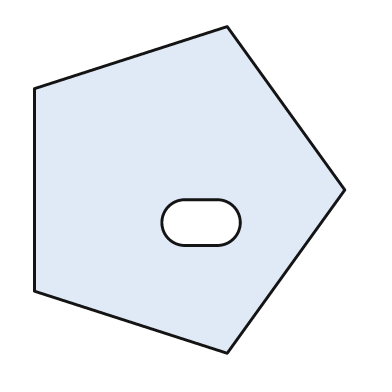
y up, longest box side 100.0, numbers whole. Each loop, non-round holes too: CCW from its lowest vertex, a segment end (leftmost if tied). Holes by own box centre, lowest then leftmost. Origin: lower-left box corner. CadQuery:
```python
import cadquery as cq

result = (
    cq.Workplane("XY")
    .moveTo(59.0, 0.0)
    .lineTo(95.0, 50.0)
    .lineTo(59.0, 100.0)
    .lineTo(0.0, 81.0)
    .lineTo(0.0, 19.0)
    .close()
    .moveTo(46.0, 33.0)
    .lineTo(56.0, 33.0)
    .threePointArc((63.0, 40.0), (56.0, 47.0))
    .lineTo(46.0, 47.0)
    .threePointArc((39.0, 40.0), (46.0, 33.0))
    .close()
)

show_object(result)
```